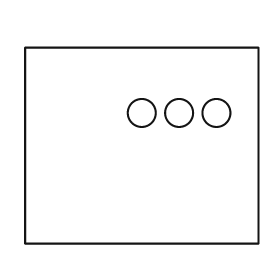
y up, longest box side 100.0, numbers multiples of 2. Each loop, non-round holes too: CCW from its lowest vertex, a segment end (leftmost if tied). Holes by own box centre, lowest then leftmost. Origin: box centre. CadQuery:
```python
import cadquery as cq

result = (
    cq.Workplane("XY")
    .moveTo(-50.0, -42.0)
    .lineTo(50.0, -42.0)
    .lineTo(50.0, 42.0)
    .lineTo(-50.0, 42.0)
    .close()
    .moveTo(0.0, 14.0)
    .circle(6.0)
    .moveTo(16.0, 14.0)
    .circle(6.0)
    .moveTo(32.0, 14.0)
    .circle(6.0)
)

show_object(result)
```